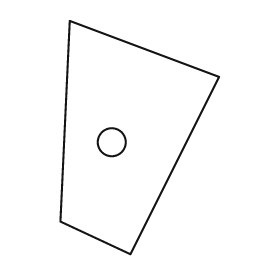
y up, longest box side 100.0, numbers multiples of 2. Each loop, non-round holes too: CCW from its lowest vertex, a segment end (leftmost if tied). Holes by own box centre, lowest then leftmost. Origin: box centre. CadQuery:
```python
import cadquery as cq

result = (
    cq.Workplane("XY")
    .moveTo(-4.0, -50.0)
    .lineTo(34.0, 26.0)
    .lineTo(-30.0, 50.0)
    .lineTo(-34.0, -36.0)
    .close()
    .moveTo(-12.0, -2.0)
    .circle(6.0)
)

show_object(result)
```